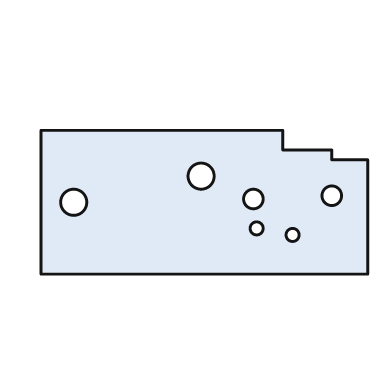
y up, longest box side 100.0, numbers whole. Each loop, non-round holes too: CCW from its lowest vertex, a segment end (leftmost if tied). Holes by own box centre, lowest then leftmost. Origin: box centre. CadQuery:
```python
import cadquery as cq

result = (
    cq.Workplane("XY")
    .moveTo(-50.0, -22.0)
    .lineTo(50.0, -22.0)
    .lineTo(50.0, 13.0)
    .lineTo(39.0, 13.0)
    .lineTo(39.0, 16.0)
    .lineTo(24.0, 16.0)
    .lineTo(24.0, 22.0)
    .lineTo(-50.0, 22.0)
    .close()
    .moveTo(27.0, -10.0)
    .circle(2.0)
    .moveTo(16.0, -8.0)
    .circle(2.0)
    .moveTo(-40.0, 0.0)
    .circle(4.0)
    .moveTo(15.0, 1.0)
    .circle(3.0)
    .moveTo(39.0, 2.0)
    .circle(3.0)
    .moveTo(-1.0, 8.0)
    .circle(4.0)
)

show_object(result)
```